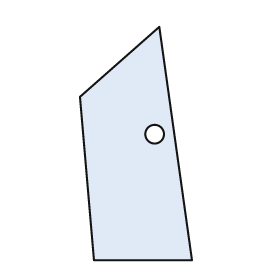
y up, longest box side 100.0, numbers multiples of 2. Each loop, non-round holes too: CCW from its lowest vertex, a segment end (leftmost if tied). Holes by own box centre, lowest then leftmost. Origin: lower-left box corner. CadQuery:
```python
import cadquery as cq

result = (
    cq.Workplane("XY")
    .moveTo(6.0, 0.0)
    .lineTo(48.0, 0.0)
    .lineTo(34.0, 100.0)
    .lineTo(0.0, 70.0)
    .close()
    .moveTo(32.0, 54.0)
    .circle(4.0)
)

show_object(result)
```